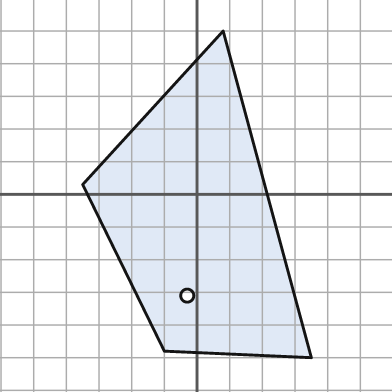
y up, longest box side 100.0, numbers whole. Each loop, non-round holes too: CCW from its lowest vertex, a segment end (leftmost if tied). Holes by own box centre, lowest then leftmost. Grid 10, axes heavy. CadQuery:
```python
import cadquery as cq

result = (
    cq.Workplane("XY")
    .moveTo(35.0, -50.0)
    .lineTo(8.0, 50.0)
    .lineTo(-35.0, 3.0)
    .lineTo(-10.0, -48.0)
    .close()
    .moveTo(-3.0, -31.0)
    .circle(2.0)
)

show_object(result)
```